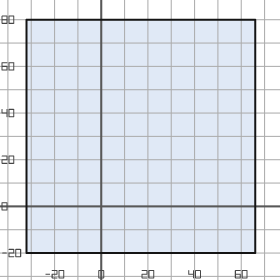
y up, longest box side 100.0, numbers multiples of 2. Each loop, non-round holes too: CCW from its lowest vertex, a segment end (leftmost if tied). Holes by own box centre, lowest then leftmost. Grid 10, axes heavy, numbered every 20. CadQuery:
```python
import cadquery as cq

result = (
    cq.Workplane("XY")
    .moveTo(-32.0, -20.0)
    .lineTo(66.0, -20.0)
    .lineTo(66.0, 80.0)
    .lineTo(-32.0, 80.0)
    .close()
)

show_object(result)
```